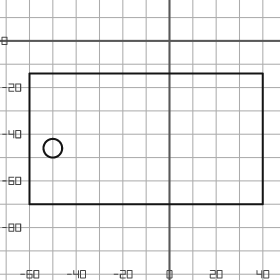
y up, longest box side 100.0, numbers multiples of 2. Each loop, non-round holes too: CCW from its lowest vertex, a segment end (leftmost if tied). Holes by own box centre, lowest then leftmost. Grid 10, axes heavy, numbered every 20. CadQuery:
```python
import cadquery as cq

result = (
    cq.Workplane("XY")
    .moveTo(-60.0, -70.0)
    .lineTo(40.0, -70.0)
    .lineTo(40.0, -14.0)
    .lineTo(-60.0, -14.0)
    .close()
    .moveTo(-50.0, -46.0)
    .circle(4.0)
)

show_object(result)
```